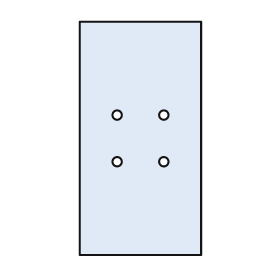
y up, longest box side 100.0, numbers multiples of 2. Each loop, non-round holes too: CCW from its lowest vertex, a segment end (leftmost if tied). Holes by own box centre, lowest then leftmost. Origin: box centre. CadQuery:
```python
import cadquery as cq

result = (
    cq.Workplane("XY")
    .moveTo(-26.0, -50.0)
    .lineTo(26.0, -50.0)
    .lineTo(26.0, 50.0)
    .lineTo(-26.0, 50.0)
    .close()
    .moveTo(-10.0, -10.0)
    .circle(2.0)
    .moveTo(10.0, -10.0)
    .circle(2.0)
    .moveTo(-10.0, 10.0)
    .circle(2.0)
    .moveTo(10.0, 10.0)
    .circle(2.0)
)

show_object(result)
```